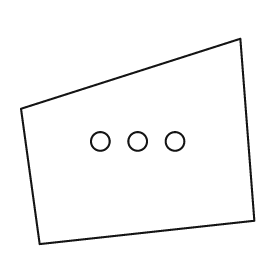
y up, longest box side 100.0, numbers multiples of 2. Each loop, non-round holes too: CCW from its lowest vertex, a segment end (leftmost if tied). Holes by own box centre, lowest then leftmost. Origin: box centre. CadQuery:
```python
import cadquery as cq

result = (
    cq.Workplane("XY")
    .moveTo(-42.0, -44.0)
    .lineTo(50.0, -34.0)
    .lineTo(44.0, 44.0)
    .lineTo(-50.0, 14.0)
    .close()
    .moveTo(-16.0, 0.0)
    .circle(4.0)
    .moveTo(0.0, 0.0)
    .circle(4.0)
    .moveTo(16.0, 0.0)
    .circle(4.0)
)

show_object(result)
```